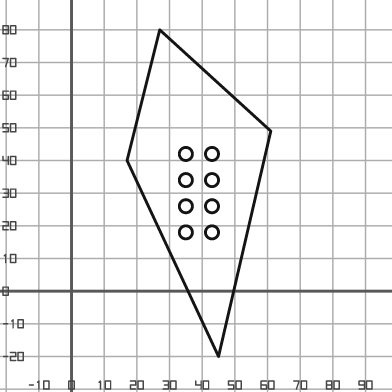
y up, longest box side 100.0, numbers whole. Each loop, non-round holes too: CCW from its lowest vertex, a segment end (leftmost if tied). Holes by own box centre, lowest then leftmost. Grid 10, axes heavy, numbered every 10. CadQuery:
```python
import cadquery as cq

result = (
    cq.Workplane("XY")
    .moveTo(45.0, -20.0)
    .lineTo(61.0, 49.0)
    .lineTo(27.0, 80.0)
    .lineTo(17.0, 40.0)
    .close()
    .moveTo(35.0, 18.0)
    .circle(2.0)
    .moveTo(43.0, 18.0)
    .circle(2.0)
    .moveTo(35.0, 26.0)
    .circle(2.0)
    .moveTo(43.0, 26.0)
    .circle(2.0)
    .moveTo(35.0, 34.0)
    .circle(2.0)
    .moveTo(43.0, 34.0)
    .circle(2.0)
    .moveTo(35.0, 42.0)
    .circle(2.0)
    .moveTo(43.0, 42.0)
    .circle(2.0)
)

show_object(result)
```